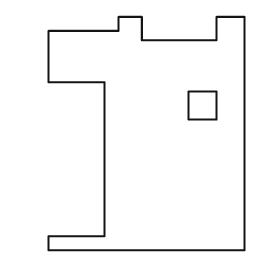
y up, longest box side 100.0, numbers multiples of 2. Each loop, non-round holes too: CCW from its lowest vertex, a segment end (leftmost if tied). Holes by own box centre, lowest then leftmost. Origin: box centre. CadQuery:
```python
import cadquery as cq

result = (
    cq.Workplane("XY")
    .moveTo(-42.0, -50.0)
    .lineTo(42.0, -50.0)
    .lineTo(42.0, 50.0)
    .lineTo(30.0, 50.0)
    .lineTo(30.0, 40.0)
    .lineTo(-2.0, 40.0)
    .lineTo(-2.0, 50.0)
    .lineTo(-12.0, 50.0)
    .lineTo(-12.0, 44.0)
    .lineTo(-42.0, 44.0)
    .lineTo(-42.0, 22.0)
    .lineTo(-18.0, 22.0)
    .lineTo(-18.0, -44.0)
    .lineTo(-42.0, -44.0)
    .close()
    .moveTo(18.0, 6.0)
    .lineTo(30.0, 6.0)
    .lineTo(30.0, 18.0)
    .lineTo(18.0, 18.0)
    .close()
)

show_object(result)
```